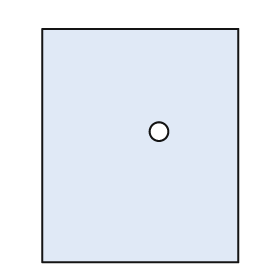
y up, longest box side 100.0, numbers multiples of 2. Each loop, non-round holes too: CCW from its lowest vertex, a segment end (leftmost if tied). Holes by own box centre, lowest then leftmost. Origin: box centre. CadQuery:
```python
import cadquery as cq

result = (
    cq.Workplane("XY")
    .moveTo(-42.0, -50.0)
    .lineTo(42.0, -50.0)
    .lineTo(42.0, 50.0)
    .lineTo(-42.0, 50.0)
    .close()
    .moveTo(8.0, 6.0)
    .circle(4.0)
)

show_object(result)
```